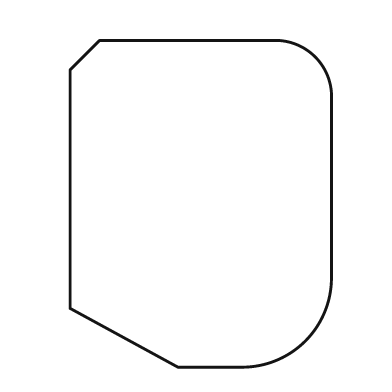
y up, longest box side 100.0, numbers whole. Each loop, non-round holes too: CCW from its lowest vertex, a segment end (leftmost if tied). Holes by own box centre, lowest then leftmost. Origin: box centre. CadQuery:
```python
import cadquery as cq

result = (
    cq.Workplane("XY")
    .moveTo(-7.0, -50.0)
    .lineTo(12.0, -50.0)
    .threePointArc((32.0, -42.0), (40.0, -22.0))
    .lineTo(40.0, 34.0)
    .threePointArc((35.0, 45.0), (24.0, 50.0))
    .lineTo(-31.0, 50.0)
    .lineTo(-40.0, 41.0)
    .lineTo(-40.0, -32.0)
    .close()
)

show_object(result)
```